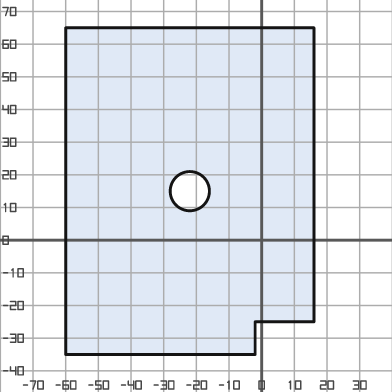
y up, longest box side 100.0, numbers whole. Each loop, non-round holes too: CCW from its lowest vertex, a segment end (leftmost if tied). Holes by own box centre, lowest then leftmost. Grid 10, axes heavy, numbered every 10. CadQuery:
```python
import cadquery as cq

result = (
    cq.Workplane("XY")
    .moveTo(-60.0, -35.0)
    .lineTo(-2.0, -35.0)
    .lineTo(-2.0, -25.0)
    .lineTo(16.0, -25.0)
    .lineTo(16.0, 65.0)
    .lineTo(-60.0, 65.0)
    .close()
    .moveTo(-22.0, 15.0)
    .circle(6.0)
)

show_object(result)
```